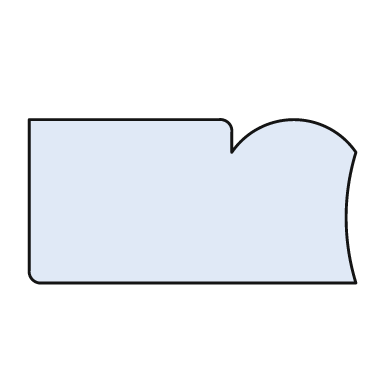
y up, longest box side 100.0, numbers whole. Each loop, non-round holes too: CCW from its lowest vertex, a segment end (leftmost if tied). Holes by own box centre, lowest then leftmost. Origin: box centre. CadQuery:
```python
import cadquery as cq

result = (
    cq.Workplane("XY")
    .moveTo(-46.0, -25.0)
    .lineTo(50.0, -25.0)
    .threePointArc((47.0, -5.0), (50.0, 15.0))
    .threePointArc((31.0, 25.0), (12.0, 15.0))
    .lineTo(12.0, 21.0)
    .threePointArc((11.0, 24.0), (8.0, 25.0))
    .lineTo(-50.0, 25.0)
    .lineTo(-50.0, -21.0)
    .threePointArc((-49.0, -24.0), (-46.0, -25.0))
    .close()
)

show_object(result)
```